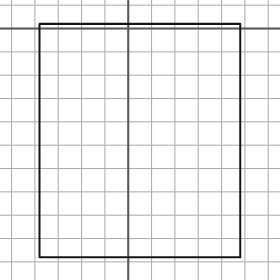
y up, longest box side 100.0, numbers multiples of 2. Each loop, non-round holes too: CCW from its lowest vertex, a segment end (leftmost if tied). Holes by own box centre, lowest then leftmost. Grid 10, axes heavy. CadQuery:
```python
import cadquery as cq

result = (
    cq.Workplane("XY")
    .moveTo(-38.0, -98.0)
    .lineTo(48.0, -98.0)
    .lineTo(48.0, 2.0)
    .lineTo(-38.0, 2.0)
    .close()
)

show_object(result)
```